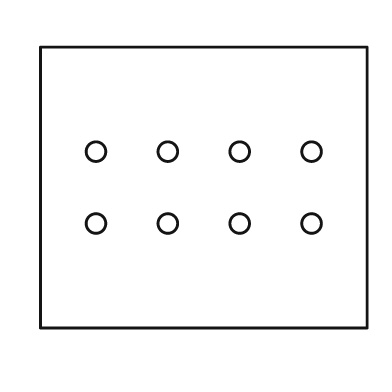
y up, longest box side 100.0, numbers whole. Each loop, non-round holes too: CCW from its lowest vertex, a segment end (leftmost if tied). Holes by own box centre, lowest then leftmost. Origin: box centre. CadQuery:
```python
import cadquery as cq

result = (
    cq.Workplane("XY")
    .moveTo(-50.0, -43.0)
    .lineTo(50.0, -43.0)
    .lineTo(50.0, 43.0)
    .lineTo(-50.0, 43.0)
    .close()
    .moveTo(-33.0, -11.0)
    .circle(3.0)
    .moveTo(-11.0, -11.0)
    .circle(3.0)
    .moveTo(11.0, -11.0)
    .circle(3.0)
    .moveTo(33.0, -11.0)
    .circle(3.0)
    .moveTo(-33.0, 11.0)
    .circle(3.0)
    .moveTo(-11.0, 11.0)
    .circle(3.0)
    .moveTo(11.0, 11.0)
    .circle(3.0)
    .moveTo(33.0, 11.0)
    .circle(3.0)
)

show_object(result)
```